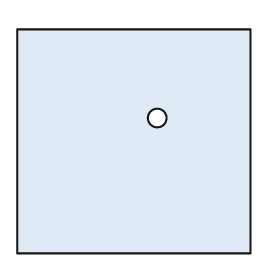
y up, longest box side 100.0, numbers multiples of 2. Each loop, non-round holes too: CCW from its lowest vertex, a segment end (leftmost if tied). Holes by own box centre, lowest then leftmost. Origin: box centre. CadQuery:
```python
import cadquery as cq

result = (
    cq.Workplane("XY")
    .moveTo(-50.0, -48.0)
    .lineTo(50.0, -48.0)
    .lineTo(50.0, 48.0)
    .lineTo(-50.0, 48.0)
    .close()
    .moveTo(10.0, 10.0)
    .circle(4.0)
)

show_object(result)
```